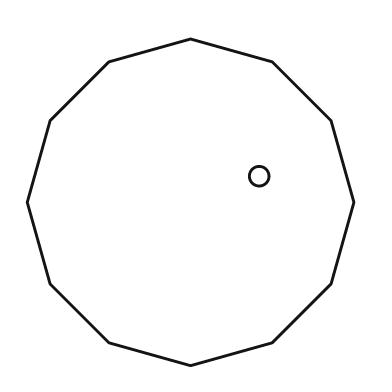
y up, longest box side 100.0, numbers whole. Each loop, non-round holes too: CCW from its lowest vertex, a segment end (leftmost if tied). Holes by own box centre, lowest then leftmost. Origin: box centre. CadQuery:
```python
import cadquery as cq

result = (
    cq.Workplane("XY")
    .moveTo(0.0, -50.0)
    .lineTo(25.0, -43.0)
    .lineTo(43.0, -25.0)
    .lineTo(50.0, 0.0)
    .lineTo(43.0, 25.0)
    .lineTo(25.0, 43.0)
    .lineTo(0.0, 50.0)
    .lineTo(-25.0, 43.0)
    .lineTo(-43.0, 25.0)
    .lineTo(-50.0, 0.0)
    .lineTo(-43.0, -25.0)
    .lineTo(-25.0, -43.0)
    .close()
    .moveTo(21.0, 8.0)
    .circle(3.0)
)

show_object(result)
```